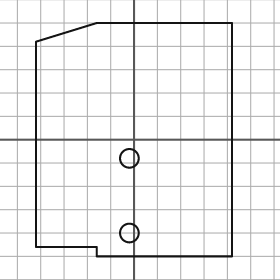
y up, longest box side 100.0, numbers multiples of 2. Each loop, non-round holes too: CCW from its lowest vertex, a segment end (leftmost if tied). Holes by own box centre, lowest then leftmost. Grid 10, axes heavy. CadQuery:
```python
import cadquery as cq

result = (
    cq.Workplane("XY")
    .moveTo(-16.0, -50.0)
    .lineTo(42.0, -50.0)
    .lineTo(42.0, 50.0)
    .lineTo(-16.0, 50.0)
    .lineTo(-42.0, 42.0)
    .lineTo(-42.0, -46.0)
    .lineTo(-16.0, -46.0)
    .close()
    .moveTo(-2.0, -40.0)
    .circle(4.0)
    .moveTo(-2.0, -8.0)
    .circle(4.0)
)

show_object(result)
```